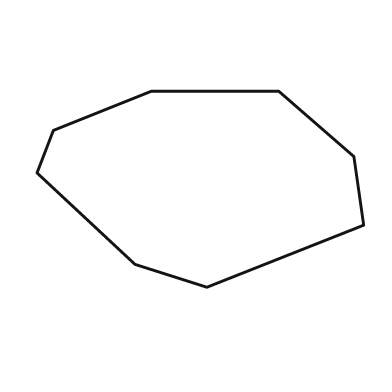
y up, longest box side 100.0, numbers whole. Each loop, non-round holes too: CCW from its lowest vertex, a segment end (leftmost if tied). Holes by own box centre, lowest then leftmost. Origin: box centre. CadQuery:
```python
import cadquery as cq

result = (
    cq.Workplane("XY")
    .moveTo(2.0, -30.0)
    .lineTo(50.0, -11.0)
    .lineTo(47.0, 10.0)
    .lineTo(24.0, 30.0)
    .lineTo(-15.0, 30.0)
    .lineTo(-45.0, 18.0)
    .lineTo(-50.0, 5.0)
    .lineTo(-20.0, -23.0)
    .close()
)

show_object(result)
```